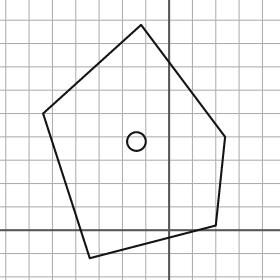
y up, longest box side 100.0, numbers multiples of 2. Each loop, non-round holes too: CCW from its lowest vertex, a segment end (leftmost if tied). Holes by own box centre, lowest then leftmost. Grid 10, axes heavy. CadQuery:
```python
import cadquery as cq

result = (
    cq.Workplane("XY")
    .moveTo(-34.0, -12.0)
    .lineTo(20.0, 2.0)
    .lineTo(24.0, 40.0)
    .lineTo(-12.0, 88.0)
    .lineTo(-54.0, 50.0)
    .close()
    .moveTo(-14.0, 38.0)
    .circle(4.0)
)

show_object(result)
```